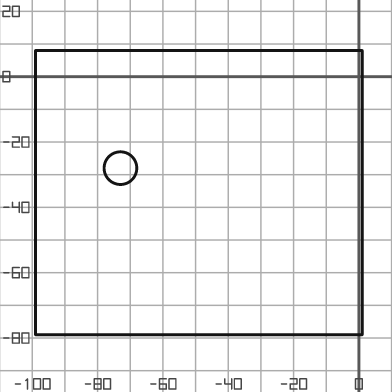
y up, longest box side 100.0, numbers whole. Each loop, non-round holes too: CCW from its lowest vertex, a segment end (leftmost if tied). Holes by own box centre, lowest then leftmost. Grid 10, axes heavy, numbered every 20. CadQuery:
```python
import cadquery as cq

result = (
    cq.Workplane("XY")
    .moveTo(-99.0, -79.0)
    .lineTo(1.0, -79.0)
    .lineTo(1.0, 8.0)
    .lineTo(-99.0, 8.0)
    .close()
    .moveTo(-73.0, -28.0)
    .circle(5.0)
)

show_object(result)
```